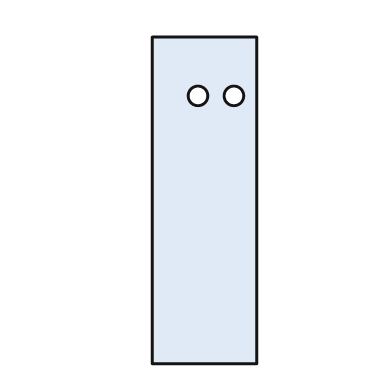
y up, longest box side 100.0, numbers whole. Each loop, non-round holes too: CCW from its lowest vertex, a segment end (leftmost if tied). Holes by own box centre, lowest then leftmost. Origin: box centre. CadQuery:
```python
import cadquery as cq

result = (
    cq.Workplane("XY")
    .moveTo(-16.0, -50.0)
    .lineTo(16.0, -50.0)
    .lineTo(16.0, 50.0)
    .lineTo(-16.0, 50.0)
    .close()
    .moveTo(-2.0, 32.0)
    .circle(3.0)
    .moveTo(9.0, 32.0)
    .circle(3.0)
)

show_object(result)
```